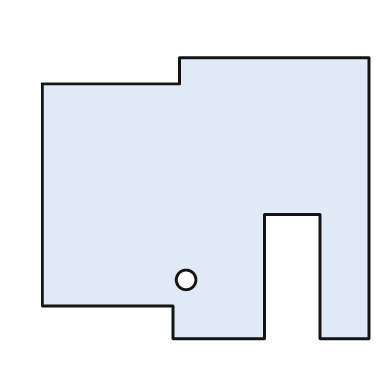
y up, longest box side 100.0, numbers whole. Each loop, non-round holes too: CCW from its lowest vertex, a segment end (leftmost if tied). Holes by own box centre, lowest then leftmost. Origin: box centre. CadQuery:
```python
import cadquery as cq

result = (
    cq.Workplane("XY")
    .moveTo(-10.0, -43.0)
    .lineTo(18.0, -43.0)
    .lineTo(18.0, -5.0)
    .lineTo(35.0, -5.0)
    .lineTo(35.0, -43.0)
    .lineTo(50.0, -43.0)
    .lineTo(50.0, 43.0)
    .lineTo(-8.0, 43.0)
    .lineTo(-8.0, 35.0)
    .lineTo(-50.0, 35.0)
    .lineTo(-50.0, -33.0)
    .lineTo(-10.0, -33.0)
    .close()
    .moveTo(-6.0, -25.0)
    .circle(3.0)
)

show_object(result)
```